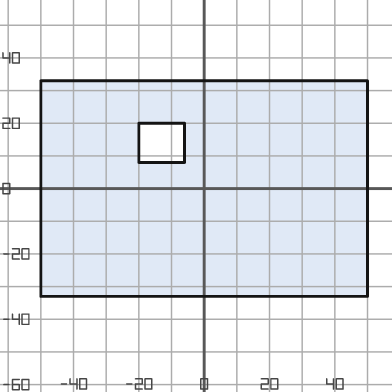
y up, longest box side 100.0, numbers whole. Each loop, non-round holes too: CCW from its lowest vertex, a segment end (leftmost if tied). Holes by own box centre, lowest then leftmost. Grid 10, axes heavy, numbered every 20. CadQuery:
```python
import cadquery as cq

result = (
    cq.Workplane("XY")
    .moveTo(-50.0, -33.0)
    .lineTo(50.0, -33.0)
    .lineTo(50.0, 33.0)
    .lineTo(-50.0, 33.0)
    .close()
    .moveTo(-20.0, 8.0)
    .lineTo(-6.0, 8.0)
    .lineTo(-6.0, 20.0)
    .lineTo(-20.0, 20.0)
    .close()
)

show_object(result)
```